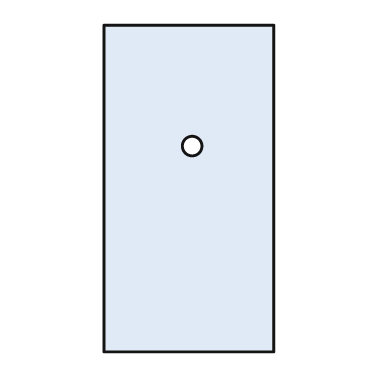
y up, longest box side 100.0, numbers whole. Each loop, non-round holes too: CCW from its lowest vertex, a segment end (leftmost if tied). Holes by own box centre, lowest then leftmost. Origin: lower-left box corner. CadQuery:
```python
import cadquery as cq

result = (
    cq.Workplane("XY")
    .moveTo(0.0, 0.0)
    .lineTo(52.0, 0.0)
    .lineTo(52.0, 100.0)
    .lineTo(0.0, 100.0)
    .close()
    .moveTo(27.0, 63.0)
    .circle(3.0)
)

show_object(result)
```